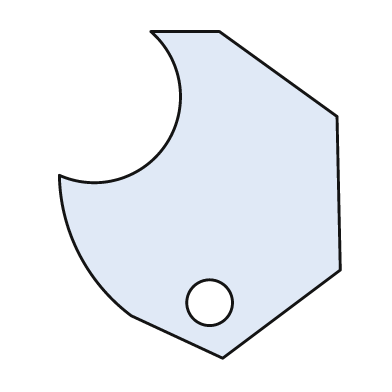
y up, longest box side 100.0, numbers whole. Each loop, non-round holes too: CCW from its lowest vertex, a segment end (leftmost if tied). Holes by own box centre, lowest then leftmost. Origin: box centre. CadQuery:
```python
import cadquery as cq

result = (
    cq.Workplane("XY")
    .moveTo(7.0, -50.0)
    .lineTo(43.0, -23.0)
    .lineTo(42.0, 24.0)
    .lineTo(6.0, 50.0)
    .lineTo(-15.0, 50.0)
    .threePointArc((-10.0, 16.0), (-43.0, 6.0))
    .threePointArc((-37.0, -18.0), (-21.0, -37.0))
    .close()
    .moveTo(3.0, -33.0)
    .circle(7.0)
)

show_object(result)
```